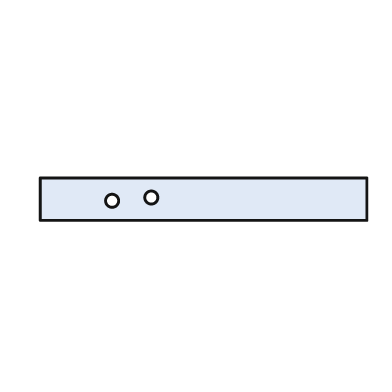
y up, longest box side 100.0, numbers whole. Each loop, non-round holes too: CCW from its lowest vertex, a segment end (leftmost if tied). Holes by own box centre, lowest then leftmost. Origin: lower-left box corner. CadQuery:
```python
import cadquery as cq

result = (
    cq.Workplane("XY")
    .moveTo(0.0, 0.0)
    .lineTo(100.0, 0.0)
    .lineTo(100.0, 13.0)
    .lineTo(0.0, 13.0)
    .close()
    .moveTo(22.0, 6.0)
    .circle(2.0)
    .moveTo(34.0, 7.0)
    .circle(2.0)
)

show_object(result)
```